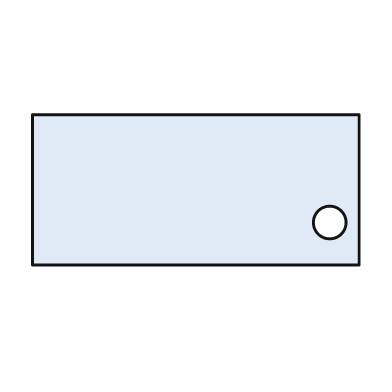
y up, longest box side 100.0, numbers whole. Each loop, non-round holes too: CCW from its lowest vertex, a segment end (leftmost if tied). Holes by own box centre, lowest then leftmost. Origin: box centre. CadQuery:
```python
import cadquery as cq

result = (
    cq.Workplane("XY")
    .moveTo(-50.0, -23.0)
    .lineTo(50.0, -23.0)
    .lineTo(50.0, 23.0)
    .lineTo(-50.0, 23.0)
    .close()
    .moveTo(41.0, -10.0)
    .circle(5.0)
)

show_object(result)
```